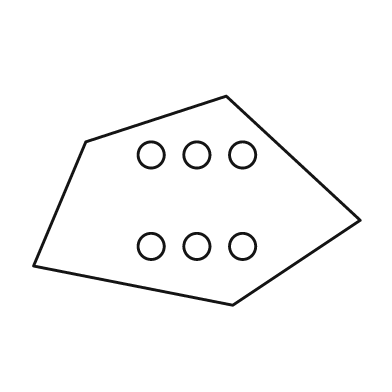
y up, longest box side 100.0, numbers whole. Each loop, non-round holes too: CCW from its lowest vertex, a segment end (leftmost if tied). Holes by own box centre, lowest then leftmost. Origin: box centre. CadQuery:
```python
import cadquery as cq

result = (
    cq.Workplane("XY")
    .moveTo(11.0, -32.0)
    .lineTo(50.0, -6.0)
    .lineTo(9.0, 32.0)
    .lineTo(-34.0, 18.0)
    .lineTo(-50.0, -20.0)
    .close()
    .moveTo(-14.0, -14.0)
    .circle(4.0)
    .moveTo(0.0, -14.0)
    .circle(4.0)
    .moveTo(14.0, -14.0)
    .circle(4.0)
    .moveTo(-14.0, 14.0)
    .circle(4.0)
    .moveTo(0.0, 14.0)
    .circle(4.0)
    .moveTo(14.0, 14.0)
    .circle(4.0)
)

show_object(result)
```